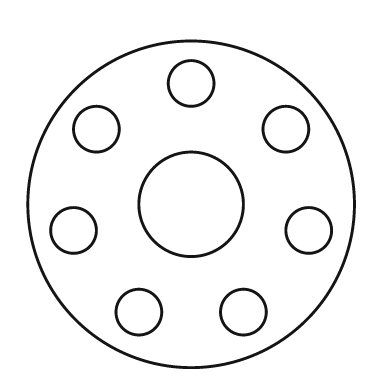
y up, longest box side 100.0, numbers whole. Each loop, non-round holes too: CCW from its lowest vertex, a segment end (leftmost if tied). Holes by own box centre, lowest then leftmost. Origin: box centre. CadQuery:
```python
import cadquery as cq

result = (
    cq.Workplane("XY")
    .moveTo(0.0, 0.0)
    .circle(50.0)
    .moveTo(-16.0, -33.0)
    .circle(7.0)
    .moveTo(16.0, -33.0)
    .circle(7.0)
    .moveTo(-36.0, -8.0)
    .circle(7.0)
    .moveTo(36.0, -8.0)
    .circle(7.0)
    .moveTo(0.0, 0.0)
    .circle(16.0)
    .moveTo(-29.0, 23.0)
    .circle(7.0)
    .moveTo(29.0, 23.0)
    .circle(7.0)
    .moveTo(0.0, 37.0)
    .circle(7.0)
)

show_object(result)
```